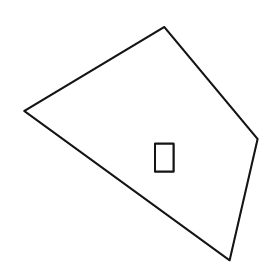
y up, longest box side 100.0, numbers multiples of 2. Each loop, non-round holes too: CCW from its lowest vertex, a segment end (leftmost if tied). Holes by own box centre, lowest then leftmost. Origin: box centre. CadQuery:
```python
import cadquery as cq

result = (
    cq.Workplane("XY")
    .moveTo(38.0, -50.0)
    .lineTo(50.0, 2.0)
    .lineTo(10.0, 50.0)
    .lineTo(-50.0, 14.0)
    .close()
    .moveTo(6.0, -12.0)
    .lineTo(14.0, -12.0)
    .lineTo(14.0, 0.0)
    .lineTo(6.0, 0.0)
    .close()
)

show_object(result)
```